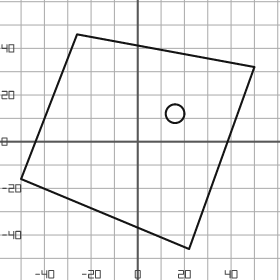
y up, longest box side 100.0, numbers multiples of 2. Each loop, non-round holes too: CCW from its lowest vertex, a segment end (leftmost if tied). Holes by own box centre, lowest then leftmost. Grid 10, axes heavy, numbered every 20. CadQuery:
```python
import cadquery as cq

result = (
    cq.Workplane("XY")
    .moveTo(22.0, -46.0)
    .lineTo(50.0, 32.0)
    .lineTo(-26.0, 46.0)
    .lineTo(-50.0, -16.0)
    .close()
    .moveTo(16.0, 12.0)
    .circle(4.0)
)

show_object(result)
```